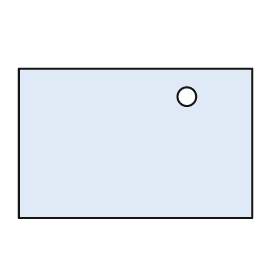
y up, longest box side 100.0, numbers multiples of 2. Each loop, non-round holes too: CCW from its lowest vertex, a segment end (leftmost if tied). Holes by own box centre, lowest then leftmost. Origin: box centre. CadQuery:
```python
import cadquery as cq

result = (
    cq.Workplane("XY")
    .moveTo(-50.0, -32.0)
    .lineTo(50.0, -32.0)
    .lineTo(50.0, 32.0)
    .lineTo(-50.0, 32.0)
    .close()
    .moveTo(22.0, 20.0)
    .circle(4.0)
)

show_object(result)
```